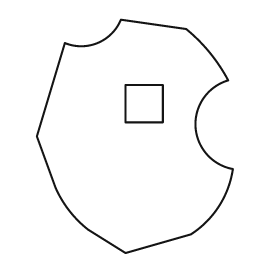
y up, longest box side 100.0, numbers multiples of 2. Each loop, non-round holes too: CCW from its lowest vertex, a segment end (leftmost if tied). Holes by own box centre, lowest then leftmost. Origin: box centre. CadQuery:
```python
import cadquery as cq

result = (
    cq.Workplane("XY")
    .moveTo(-4.0, -50.0)
    .lineTo(24.0, -42.0)
    .threePointArc((36.0, -30.0), (42.0, -14.0))
    .threePointArc((26.0, 4.0), (40.0, 24.0))
    .threePointArc((32.0, 36.0), (22.0, 46.0))
    .lineTo(-6.0, 50.0)
    .threePointArc((-16.0, 40.0), (-30.0, 40.0))
    .lineTo(-42.0, 0.0)
    .lineTo(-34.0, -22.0)
    .threePointArc((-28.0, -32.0), (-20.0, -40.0))
    .close()
    .moveTo(-4.0, 6.0)
    .lineTo(12.0, 6.0)
    .lineTo(12.0, 22.0)
    .lineTo(-4.0, 22.0)
    .close()
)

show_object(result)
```